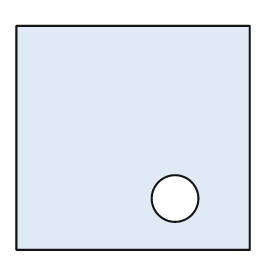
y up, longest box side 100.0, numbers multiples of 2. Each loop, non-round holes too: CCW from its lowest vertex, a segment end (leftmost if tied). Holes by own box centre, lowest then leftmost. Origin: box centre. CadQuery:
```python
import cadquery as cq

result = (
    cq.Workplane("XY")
    .moveTo(-50.0, -48.0)
    .lineTo(50.0, -48.0)
    .lineTo(50.0, 48.0)
    .lineTo(-50.0, 48.0)
    .close()
    .moveTo(18.0, -26.0)
    .circle(10.0)
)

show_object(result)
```